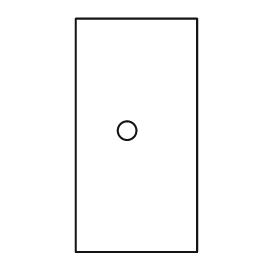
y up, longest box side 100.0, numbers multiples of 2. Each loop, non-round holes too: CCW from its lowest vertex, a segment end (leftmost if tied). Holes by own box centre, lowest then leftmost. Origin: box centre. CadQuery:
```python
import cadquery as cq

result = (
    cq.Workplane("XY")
    .moveTo(-26.0, -50.0)
    .lineTo(26.0, -50.0)
    .lineTo(26.0, 50.0)
    .lineTo(-26.0, 50.0)
    .close()
    .moveTo(-4.0, 2.0)
    .circle(4.0)
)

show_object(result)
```